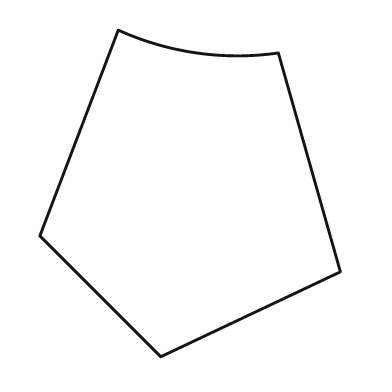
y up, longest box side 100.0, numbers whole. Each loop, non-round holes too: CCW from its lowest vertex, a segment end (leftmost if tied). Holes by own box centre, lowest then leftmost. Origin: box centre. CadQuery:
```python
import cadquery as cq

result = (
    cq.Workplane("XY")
    .moveTo(-9.0, -50.0)
    .lineTo(46.0, -24.0)
    .lineTo(27.0, 43.0)
    .threePointArc((2.0, 43.0), (-22.0, 50.0))
    .lineTo(-46.0, -13.0)
    .close()
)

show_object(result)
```